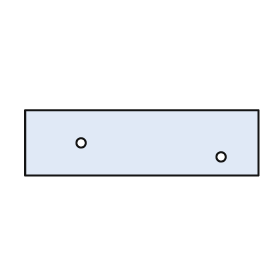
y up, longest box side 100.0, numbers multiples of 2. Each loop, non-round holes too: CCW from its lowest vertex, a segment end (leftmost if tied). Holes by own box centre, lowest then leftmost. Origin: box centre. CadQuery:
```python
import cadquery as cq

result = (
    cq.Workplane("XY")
    .moveTo(-50.0, -14.0)
    .lineTo(50.0, -14.0)
    .lineTo(50.0, 14.0)
    .lineTo(-50.0, 14.0)
    .close()
    .moveTo(34.0, -6.0)
    .circle(2.0)
    .moveTo(-26.0, 0.0)
    .circle(2.0)
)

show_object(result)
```